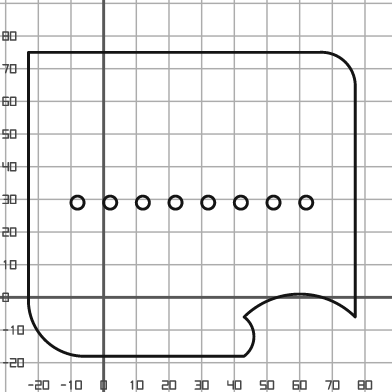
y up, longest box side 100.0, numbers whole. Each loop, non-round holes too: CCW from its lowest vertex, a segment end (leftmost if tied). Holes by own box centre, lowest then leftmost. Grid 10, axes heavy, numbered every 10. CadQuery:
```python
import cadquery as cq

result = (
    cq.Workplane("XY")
    .moveTo(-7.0, -18.0)
    .lineTo(43.0, -18.0)
    .threePointArc((46.0, -12.0), (43.0, -6.0))
    .threePointArc((60.0, 1.0), (77.0, -6.0))
    .lineTo(77.0, 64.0)
    .threePointArc((74.0, 72.0), (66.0, 75.0))
    .lineTo(-23.0, 75.0)
    .lineTo(-23.0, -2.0)
    .threePointArc((-18.0, -13.0), (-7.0, -18.0))
    .close()
    .moveTo(-8.0, 29.0)
    .circle(2.0)
    .moveTo(2.0, 29.0)
    .circle(2.0)
    .moveTo(12.0, 29.0)
    .circle(2.0)
    .moveTo(22.0, 29.0)
    .circle(2.0)
    .moveTo(32.0, 29.0)
    .circle(2.0)
    .moveTo(42.0, 29.0)
    .circle(2.0)
    .moveTo(52.0, 29.0)
    .circle(2.0)
    .moveTo(62.0, 29.0)
    .circle(2.0)
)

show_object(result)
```